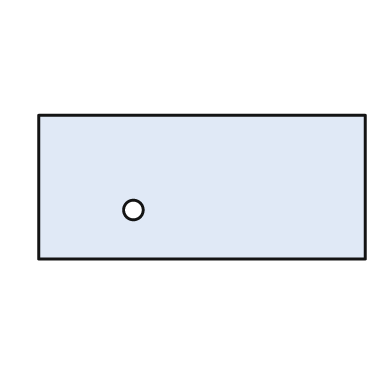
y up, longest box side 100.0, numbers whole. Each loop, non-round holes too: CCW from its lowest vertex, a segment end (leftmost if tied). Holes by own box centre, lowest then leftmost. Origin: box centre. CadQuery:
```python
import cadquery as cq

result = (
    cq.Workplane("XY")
    .moveTo(-50.0, -22.0)
    .lineTo(50.0, -22.0)
    .lineTo(50.0, 22.0)
    .lineTo(-50.0, 22.0)
    .close()
    .moveTo(-21.0, -7.0)
    .circle(3.0)
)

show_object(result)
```